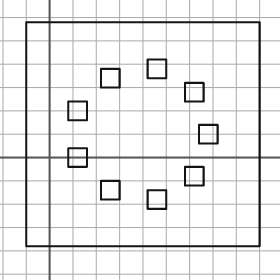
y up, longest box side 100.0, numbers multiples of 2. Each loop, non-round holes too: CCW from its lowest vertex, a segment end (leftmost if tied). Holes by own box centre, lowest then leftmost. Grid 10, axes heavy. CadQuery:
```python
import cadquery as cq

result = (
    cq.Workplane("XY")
    .moveTo(-10.0, -38.0)
    .lineTo(90.0, -38.0)
    .lineTo(90.0, 58.0)
    .lineTo(-10.0, 58.0)
    .close()
    .moveTo(42.0, -22.0)
    .lineTo(50.0, -22.0)
    .lineTo(50.0, -14.0)
    .lineTo(42.0, -14.0)
    .close()
    .moveTo(22.0, -18.0)
    .lineTo(30.0, -18.0)
    .lineTo(30.0, -10.0)
    .lineTo(22.0, -10.0)
    .close()
    .moveTo(58.0, -12.0)
    .lineTo(66.0, -12.0)
    .lineTo(66.0, -4.0)
    .lineTo(58.0, -4.0)
    .close()
    .moveTo(8.0, -4.0)
    .lineTo(16.0, -4.0)
    .lineTo(16.0, 4.0)
    .lineTo(8.0, 4.0)
    .close()
    .moveTo(64.0, 6.0)
    .lineTo(72.0, 6.0)
    .lineTo(72.0, 14.0)
    .lineTo(64.0, 14.0)
    .close()
    .moveTo(8.0, 16.0)
    .lineTo(16.0, 16.0)
    .lineTo(16.0, 24.0)
    .lineTo(8.0, 24.0)
    .close()
    .moveTo(58.0, 24.0)
    .lineTo(66.0, 24.0)
    .lineTo(66.0, 32.0)
    .lineTo(58.0, 32.0)
    .close()
    .moveTo(22.0, 30.0)
    .lineTo(30.0, 30.0)
    .lineTo(30.0, 38.0)
    .lineTo(22.0, 38.0)
    .close()
    .moveTo(42.0, 34.0)
    .lineTo(50.0, 34.0)
    .lineTo(50.0, 42.0)
    .lineTo(42.0, 42.0)
    .close()
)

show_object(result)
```